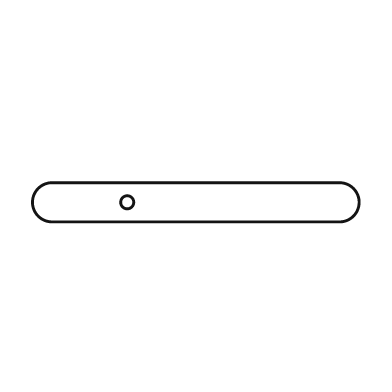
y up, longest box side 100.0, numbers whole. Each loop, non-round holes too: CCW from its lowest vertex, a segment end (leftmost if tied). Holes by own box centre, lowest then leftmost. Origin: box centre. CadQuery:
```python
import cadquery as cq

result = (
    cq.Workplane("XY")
    .moveTo(-44.0, -6.0)
    .lineTo(44.0, -6.0)
    .threePointArc((50.0, 0.0), (44.0, 6.0))
    .lineTo(-44.0, 6.0)
    .threePointArc((-50.0, 0.0), (-44.0, -6.0))
    .close()
    .moveTo(-21.0, 0.0)
    .circle(2.0)
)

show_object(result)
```